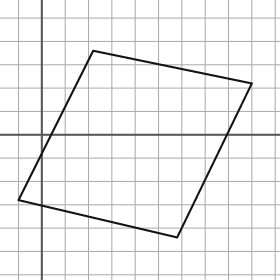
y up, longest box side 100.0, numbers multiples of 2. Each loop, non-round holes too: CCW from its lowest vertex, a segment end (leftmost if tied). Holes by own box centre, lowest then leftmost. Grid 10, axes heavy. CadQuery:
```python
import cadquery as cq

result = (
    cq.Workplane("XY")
    .moveTo(58.0, -44.0)
    .lineTo(90.0, 22.0)
    .lineTo(22.0, 36.0)
    .lineTo(-10.0, -28.0)
    .close()
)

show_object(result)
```